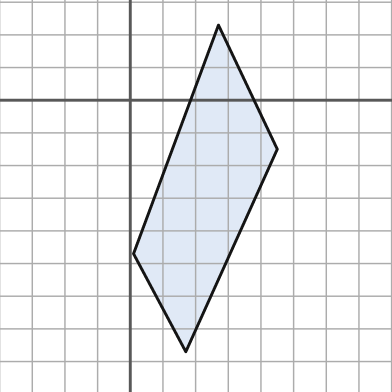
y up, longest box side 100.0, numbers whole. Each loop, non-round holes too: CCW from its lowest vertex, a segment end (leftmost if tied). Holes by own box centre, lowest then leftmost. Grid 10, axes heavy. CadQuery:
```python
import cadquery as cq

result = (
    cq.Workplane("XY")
    .moveTo(17.0, -77.0)
    .lineTo(45.0, -15.0)
    .lineTo(27.0, 23.0)
    .lineTo(1.0, -47.0)
    .close()
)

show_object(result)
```